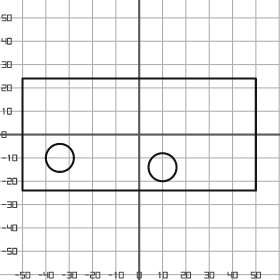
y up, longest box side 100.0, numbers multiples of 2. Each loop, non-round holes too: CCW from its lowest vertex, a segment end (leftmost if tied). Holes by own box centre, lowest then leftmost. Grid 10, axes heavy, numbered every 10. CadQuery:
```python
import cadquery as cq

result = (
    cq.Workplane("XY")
    .moveTo(-50.0, -24.0)
    .lineTo(50.0, -24.0)
    .lineTo(50.0, 24.0)
    .lineTo(-50.0, 24.0)
    .close()
    .moveTo(10.0, -14.0)
    .circle(6.0)
    .moveTo(-34.0, -10.0)
    .circle(6.0)
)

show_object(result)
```